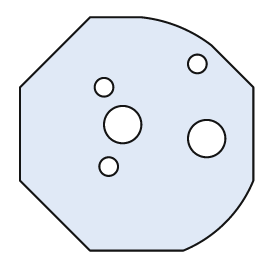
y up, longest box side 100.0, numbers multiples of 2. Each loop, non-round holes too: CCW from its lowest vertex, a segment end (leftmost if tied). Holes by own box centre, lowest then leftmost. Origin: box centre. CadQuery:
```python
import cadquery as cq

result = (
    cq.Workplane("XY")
    .moveTo(-20.0, -50.0)
    .lineTo(20.0, -50.0)
    .threePointArc((38.0, -38.0), (50.0, -20.0))
    .lineTo(50.0, 20.0)
    .lineTo(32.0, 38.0)
    .threePointArc((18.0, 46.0), (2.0, 50.0))
    .lineTo(-20.0, 50.0)
    .lineTo(-50.0, 20.0)
    .lineTo(-50.0, -20.0)
    .close()
    .moveTo(-12.0, -14.0)
    .circle(4.0)
    .moveTo(30.0, -2.0)
    .circle(8.0)
    .moveTo(-6.0, 4.0)
    .circle(8.0)
    .moveTo(-14.0, 20.0)
    .circle(4.0)
    .moveTo(26.0, 30.0)
    .circle(4.0)
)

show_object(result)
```